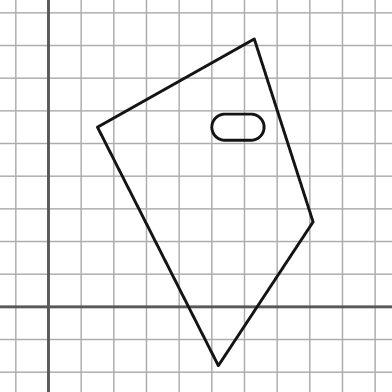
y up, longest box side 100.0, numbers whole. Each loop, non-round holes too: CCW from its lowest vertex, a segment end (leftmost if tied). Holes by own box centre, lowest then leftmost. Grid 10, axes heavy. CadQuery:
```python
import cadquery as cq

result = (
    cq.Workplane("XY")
    .moveTo(52.0, -18.0)
    .lineTo(81.0, 26.0)
    .lineTo(63.0, 82.0)
    .lineTo(15.0, 55.0)
    .close()
    .moveTo(54.0, 51.0)
    .lineTo(62.0, 51.0)
    .threePointArc((66.0, 55.0), (62.0, 59.0))
    .lineTo(54.0, 59.0)
    .threePointArc((50.0, 55.0), (54.0, 51.0))
    .close()
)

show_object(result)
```